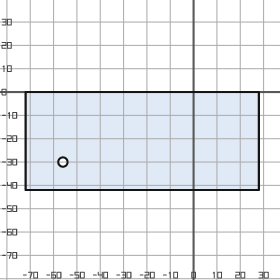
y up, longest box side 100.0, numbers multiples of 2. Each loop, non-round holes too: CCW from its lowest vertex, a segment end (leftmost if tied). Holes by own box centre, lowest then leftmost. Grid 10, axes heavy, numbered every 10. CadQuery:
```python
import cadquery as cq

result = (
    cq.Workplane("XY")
    .moveTo(-72.0, -42.0)
    .lineTo(28.0, -42.0)
    .lineTo(28.0, 0.0)
    .lineTo(-72.0, 0.0)
    .close()
    .moveTo(-56.0, -30.0)
    .circle(2.0)
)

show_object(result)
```